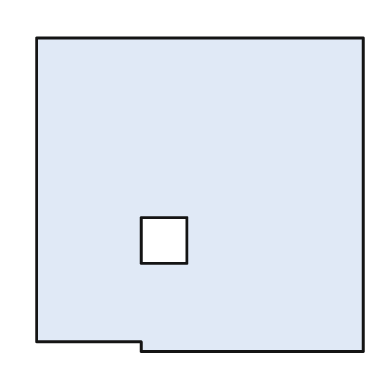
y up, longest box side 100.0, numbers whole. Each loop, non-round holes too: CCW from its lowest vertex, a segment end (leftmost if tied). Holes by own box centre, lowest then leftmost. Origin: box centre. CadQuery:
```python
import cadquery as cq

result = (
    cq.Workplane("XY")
    .moveTo(-18.0, -48.0)
    .lineTo(50.0, -48.0)
    .lineTo(50.0, 48.0)
    .lineTo(-50.0, 48.0)
    .lineTo(-50.0, -45.0)
    .lineTo(-18.0, -45.0)
    .close()
    .moveTo(-18.0, -21.0)
    .lineTo(-4.0, -21.0)
    .lineTo(-4.0, -7.0)
    .lineTo(-18.0, -7.0)
    .close()
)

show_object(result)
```